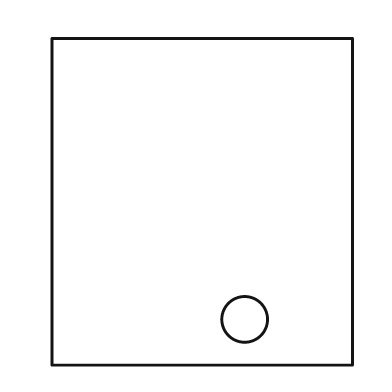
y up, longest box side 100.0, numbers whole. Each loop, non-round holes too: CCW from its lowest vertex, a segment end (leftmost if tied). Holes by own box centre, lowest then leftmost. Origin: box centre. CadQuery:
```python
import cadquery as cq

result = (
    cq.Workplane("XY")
    .moveTo(-46.0, -50.0)
    .lineTo(46.0, -50.0)
    .lineTo(46.0, 50.0)
    .lineTo(-46.0, 50.0)
    .close()
    .moveTo(13.0, -36.0)
    .circle(7.0)
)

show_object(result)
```